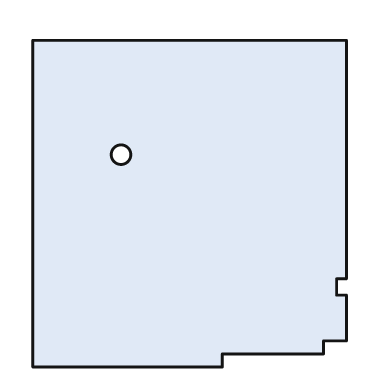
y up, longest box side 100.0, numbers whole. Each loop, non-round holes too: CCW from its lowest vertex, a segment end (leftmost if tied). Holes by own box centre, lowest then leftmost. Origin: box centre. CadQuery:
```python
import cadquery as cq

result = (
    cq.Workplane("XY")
    .moveTo(-48.0, -50.0)
    .lineTo(10.0, -50.0)
    .lineTo(10.0, -46.0)
    .lineTo(41.0, -46.0)
    .lineTo(41.0, -42.0)
    .lineTo(48.0, -42.0)
    .lineTo(48.0, -28.0)
    .lineTo(45.0, -28.0)
    .lineTo(45.0, -23.0)
    .lineTo(48.0, -23.0)
    .lineTo(48.0, 50.0)
    .lineTo(-48.0, 50.0)
    .close()
    .moveTo(-21.0, 15.0)
    .circle(3.0)
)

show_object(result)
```